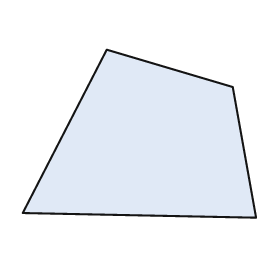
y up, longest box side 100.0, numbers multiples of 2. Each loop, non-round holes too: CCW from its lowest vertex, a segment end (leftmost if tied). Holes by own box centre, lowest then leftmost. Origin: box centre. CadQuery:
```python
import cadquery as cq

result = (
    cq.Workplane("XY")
    .moveTo(50.0, -36.0)
    .lineTo(40.0, 20.0)
    .lineTo(-14.0, 36.0)
    .lineTo(-50.0, -34.0)
    .close()
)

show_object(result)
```